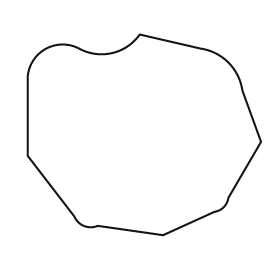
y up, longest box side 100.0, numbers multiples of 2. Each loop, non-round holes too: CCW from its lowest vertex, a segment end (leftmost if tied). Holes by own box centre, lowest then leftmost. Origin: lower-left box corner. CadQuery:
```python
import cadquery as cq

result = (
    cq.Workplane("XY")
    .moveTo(58.0, 0.0)
    .lineTo(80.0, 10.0)
    .threePointArc((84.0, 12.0), (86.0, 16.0))
    .lineTo(100.0, 40.0)
    .lineTo(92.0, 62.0)
    .threePointArc((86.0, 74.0), (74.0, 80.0))
    .lineTo(48.0, 86.0)
    .threePointArc((36.0, 78.0), (22.0, 80.0))
    .threePointArc((8.0, 80.0), (0.0, 68.0))
    .lineTo(0.0, 34.0)
    .lineTo(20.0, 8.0)
    .threePointArc((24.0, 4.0), (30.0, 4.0))
    .close()
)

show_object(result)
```